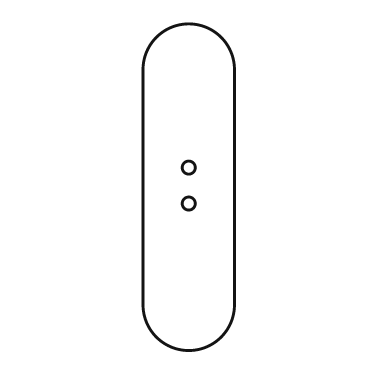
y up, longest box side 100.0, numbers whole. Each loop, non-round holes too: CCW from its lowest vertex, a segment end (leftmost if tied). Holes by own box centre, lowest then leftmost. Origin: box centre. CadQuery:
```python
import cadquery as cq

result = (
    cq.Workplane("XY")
    .moveTo(-14.0, -36.0)
    .threePointArc((0.0, -50.0), (14.0, -36.0))
    .lineTo(14.0, 36.0)
    .threePointArc((0.0, 50.0), (-14.0, 36.0))
    .close()
    .moveTo(0.0, -5.0)
    .circle(2.0)
    .moveTo(0.0, 6.0)
    .circle(2.0)
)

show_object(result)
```